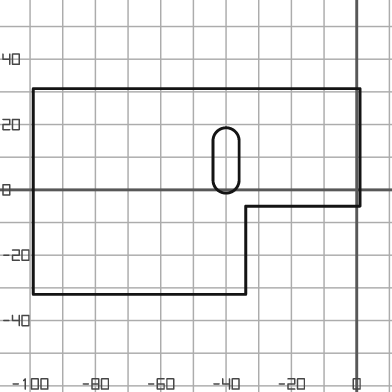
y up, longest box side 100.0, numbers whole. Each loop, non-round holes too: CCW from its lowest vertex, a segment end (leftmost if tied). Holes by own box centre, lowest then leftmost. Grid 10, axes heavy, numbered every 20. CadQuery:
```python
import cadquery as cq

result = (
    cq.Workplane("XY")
    .moveTo(-99.0, -32.0)
    .lineTo(-34.0, -32.0)
    .lineTo(-34.0, -5.0)
    .lineTo(1.0, -5.0)
    .lineTo(1.0, 31.0)
    .lineTo(-99.0, 31.0)
    .close()
    .moveTo(-44.0, 3.0)
    .threePointArc((-40.0, -1.0), (-36.0, 3.0))
    .lineTo(-36.0, 15.0)
    .threePointArc((-40.0, 19.0), (-44.0, 15.0))
    .close()
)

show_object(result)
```